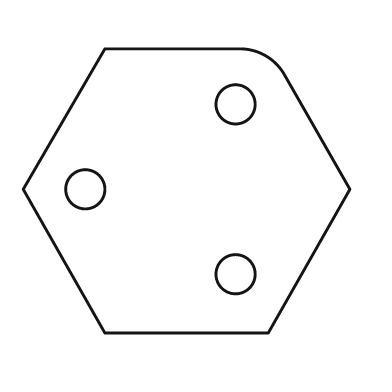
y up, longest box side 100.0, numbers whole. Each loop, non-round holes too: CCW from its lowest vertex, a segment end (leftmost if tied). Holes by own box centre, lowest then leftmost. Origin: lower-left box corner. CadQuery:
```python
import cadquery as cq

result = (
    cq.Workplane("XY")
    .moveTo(25.0, 0.0)
    .lineTo(75.0, 0.0)
    .lineTo(100.0, 44.0)
    .lineTo(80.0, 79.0)
    .threePointArc((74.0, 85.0), (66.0, 87.0))
    .lineTo(25.0, 87.0)
    .lineTo(0.0, 44.0)
    .close()
    .moveTo(65.0, 18.0)
    .circle(6.0)
    .moveTo(19.0, 44.0)
    .circle(6.0)
    .moveTo(65.0, 70.0)
    .circle(6.0)
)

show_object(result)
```